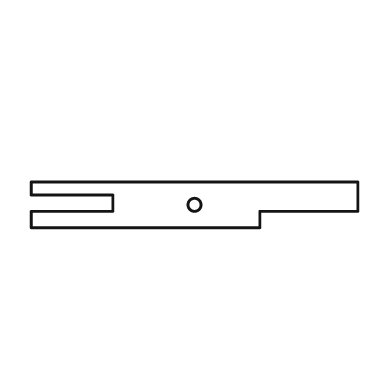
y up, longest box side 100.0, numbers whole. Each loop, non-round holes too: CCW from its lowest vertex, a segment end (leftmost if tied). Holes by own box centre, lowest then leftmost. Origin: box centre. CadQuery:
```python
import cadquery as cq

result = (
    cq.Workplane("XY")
    .moveTo(-50.0, -7.0)
    .lineTo(20.0, -7.0)
    .lineTo(20.0, -2.0)
    .lineTo(50.0, -2.0)
    .lineTo(50.0, 7.0)
    .lineTo(-50.0, 7.0)
    .lineTo(-50.0, 3.0)
    .lineTo(-25.0, 3.0)
    .lineTo(-25.0, -2.0)
    .lineTo(-50.0, -2.0)
    .close()
    .moveTo(0.0, 0.0)
    .circle(2.0)
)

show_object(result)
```